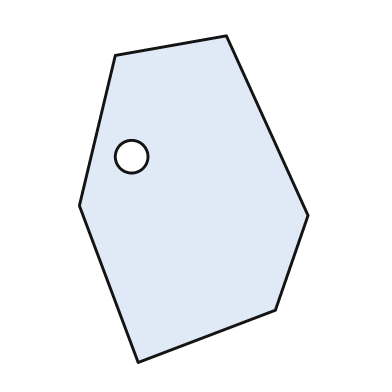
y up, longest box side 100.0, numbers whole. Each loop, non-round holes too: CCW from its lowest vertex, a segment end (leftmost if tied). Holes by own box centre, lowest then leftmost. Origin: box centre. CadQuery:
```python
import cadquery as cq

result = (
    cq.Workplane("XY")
    .moveTo(-17.0, -50.0)
    .lineTo(25.0, -34.0)
    .lineTo(35.0, -5.0)
    .lineTo(10.0, 50.0)
    .lineTo(-24.0, 44.0)
    .lineTo(-35.0, -2.0)
    .close()
    .moveTo(-19.0, 13.0)
    .circle(5.0)
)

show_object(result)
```